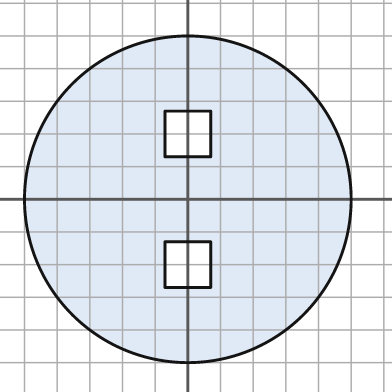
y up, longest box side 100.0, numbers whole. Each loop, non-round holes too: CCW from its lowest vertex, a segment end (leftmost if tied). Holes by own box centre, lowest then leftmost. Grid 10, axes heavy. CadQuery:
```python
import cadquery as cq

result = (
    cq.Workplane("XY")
    .moveTo(0.0, 0.0)
    .circle(50.0)
    .moveTo(-7.0, -27.0)
    .lineTo(7.0, -27.0)
    .lineTo(7.0, -13.0)
    .lineTo(-7.0, -13.0)
    .close()
    .moveTo(-7.0, 13.0)
    .lineTo(7.0, 13.0)
    .lineTo(7.0, 27.0)
    .lineTo(-7.0, 27.0)
    .close()
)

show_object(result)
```